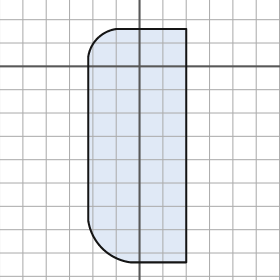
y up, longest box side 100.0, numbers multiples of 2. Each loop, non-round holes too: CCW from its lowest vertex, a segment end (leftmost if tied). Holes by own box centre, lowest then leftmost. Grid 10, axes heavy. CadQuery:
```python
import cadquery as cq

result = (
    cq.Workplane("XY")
    .moveTo(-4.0, -84.0)
    .lineTo(20.0, -84.0)
    .lineTo(20.0, 16.0)
    .lineTo(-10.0, 16.0)
    .threePointArc((-18.0, 12.0), (-22.0, 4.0))
    .lineTo(-22.0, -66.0)
    .threePointArc((-16.0, -78.0), (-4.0, -84.0))
    .close()
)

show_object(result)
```